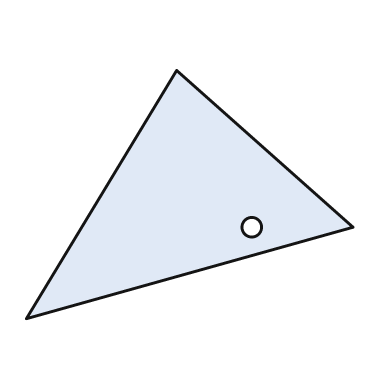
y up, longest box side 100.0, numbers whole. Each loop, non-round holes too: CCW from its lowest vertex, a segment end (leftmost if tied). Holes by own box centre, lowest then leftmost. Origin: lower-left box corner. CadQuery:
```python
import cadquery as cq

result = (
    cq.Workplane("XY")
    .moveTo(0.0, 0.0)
    .lineTo(100.0, 28.0)
    .lineTo(46.0, 76.0)
    .close()
    .moveTo(69.0, 28.0)
    .circle(3.0)
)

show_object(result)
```